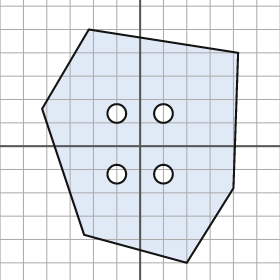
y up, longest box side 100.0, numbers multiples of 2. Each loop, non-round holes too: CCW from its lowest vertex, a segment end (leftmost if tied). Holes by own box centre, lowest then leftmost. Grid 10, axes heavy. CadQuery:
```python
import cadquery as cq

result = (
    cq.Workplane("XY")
    .moveTo(20.0, -50.0)
    .lineTo(40.0, -18.0)
    .lineTo(42.0, 40.0)
    .lineTo(-22.0, 50.0)
    .lineTo(-42.0, 16.0)
    .lineTo(-24.0, -38.0)
    .close()
    .moveTo(-10.0, -12.0)
    .circle(4.0)
    .moveTo(10.0, -12.0)
    .circle(4.0)
    .moveTo(-10.0, 14.0)
    .circle(4.0)
    .moveTo(10.0, 14.0)
    .circle(4.0)
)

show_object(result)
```